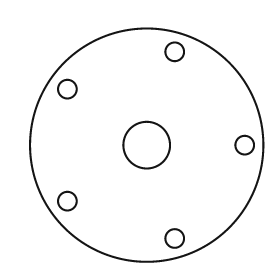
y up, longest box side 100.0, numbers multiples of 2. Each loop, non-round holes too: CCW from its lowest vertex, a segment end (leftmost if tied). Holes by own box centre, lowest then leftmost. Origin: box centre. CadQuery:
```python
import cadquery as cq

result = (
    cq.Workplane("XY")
    .moveTo(0.0, 0.0)
    .circle(50.0)
    .moveTo(12.0, -40.0)
    .circle(4.0)
    .moveTo(-34.0, -24.0)
    .circle(4.0)
    .moveTo(0.0, 0.0)
    .circle(10.0)
    .moveTo(42.0, 0.0)
    .circle(4.0)
    .moveTo(-34.0, 24.0)
    .circle(4.0)
    .moveTo(12.0, 40.0)
    .circle(4.0)
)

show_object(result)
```